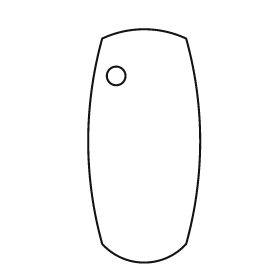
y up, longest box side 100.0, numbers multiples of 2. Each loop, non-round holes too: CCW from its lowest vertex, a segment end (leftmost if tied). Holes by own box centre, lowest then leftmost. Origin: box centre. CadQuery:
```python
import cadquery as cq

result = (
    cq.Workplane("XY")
    .moveTo(-18.0, -42.0)
    .threePointArc((0.0, -50.0), (18.0, -42.0))
    .threePointArc((24.0, 2.0), (18.0, 46.0))
    .threePointArc((0.0, 50.0), (-18.0, 46.0))
    .threePointArc((-24.0, 2.0), (-18.0, -42.0))
    .close()
    .moveTo(-12.0, 30.0)
    .circle(4.0)
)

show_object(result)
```